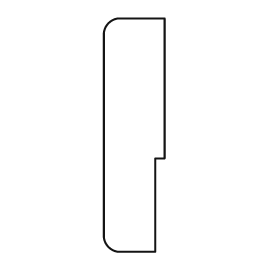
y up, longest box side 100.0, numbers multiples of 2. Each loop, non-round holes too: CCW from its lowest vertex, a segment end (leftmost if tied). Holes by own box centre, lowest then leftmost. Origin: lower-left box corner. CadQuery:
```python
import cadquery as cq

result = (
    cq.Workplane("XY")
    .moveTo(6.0, 0.0)
    .lineTo(22.0, 0.0)
    .lineTo(22.0, 40.0)
    .lineTo(26.0, 40.0)
    .lineTo(26.0, 100.0)
    .lineTo(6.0, 100.0)
    .threePointArc((2.0, 98.0), (0.0, 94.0))
    .lineTo(0.0, 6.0)
    .threePointArc((2.0, 2.0), (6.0, 0.0))
    .close()
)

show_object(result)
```